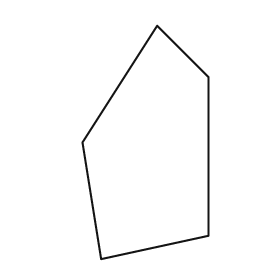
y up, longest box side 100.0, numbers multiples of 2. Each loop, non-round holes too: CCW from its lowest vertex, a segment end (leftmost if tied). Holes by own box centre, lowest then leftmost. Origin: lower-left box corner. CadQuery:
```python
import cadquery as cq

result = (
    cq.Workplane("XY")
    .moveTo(8.0, 0.0)
    .lineTo(54.0, 10.0)
    .lineTo(54.0, 78.0)
    .lineTo(32.0, 100.0)
    .lineTo(0.0, 50.0)
    .close()
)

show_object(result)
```